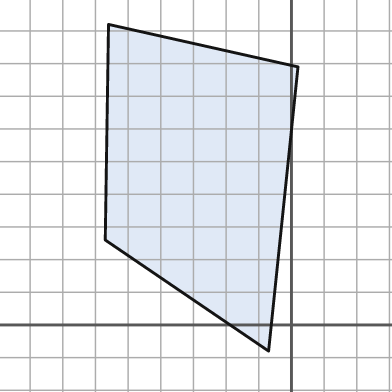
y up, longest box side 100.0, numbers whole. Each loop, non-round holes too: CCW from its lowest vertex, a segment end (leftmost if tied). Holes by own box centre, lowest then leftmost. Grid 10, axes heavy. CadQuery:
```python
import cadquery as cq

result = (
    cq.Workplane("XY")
    .moveTo(-7.0, -8.0)
    .lineTo(2.0, 79.0)
    .lineTo(-56.0, 92.0)
    .lineTo(-57.0, 26.0)
    .close()
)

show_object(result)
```